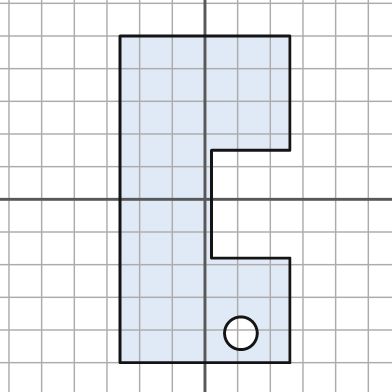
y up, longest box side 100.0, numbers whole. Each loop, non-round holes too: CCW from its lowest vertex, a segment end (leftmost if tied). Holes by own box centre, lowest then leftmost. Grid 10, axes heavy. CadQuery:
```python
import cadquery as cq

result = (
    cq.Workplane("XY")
    .moveTo(-26.0, -50.0)
    .lineTo(26.0, -50.0)
    .lineTo(26.0, -18.0)
    .lineTo(2.0, -18.0)
    .lineTo(2.0, 15.0)
    .lineTo(26.0, 15.0)
    .lineTo(26.0, 50.0)
    .lineTo(-26.0, 50.0)
    .close()
    .moveTo(11.0, -41.0)
    .circle(5.0)
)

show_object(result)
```